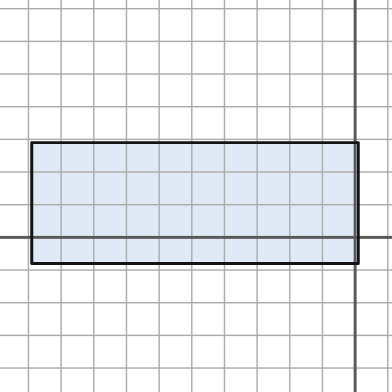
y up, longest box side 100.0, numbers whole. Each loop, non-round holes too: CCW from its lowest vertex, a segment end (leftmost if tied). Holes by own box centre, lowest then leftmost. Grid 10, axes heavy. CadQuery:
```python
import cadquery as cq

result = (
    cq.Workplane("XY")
    .moveTo(-99.0, -8.0)
    .lineTo(1.0, -8.0)
    .lineTo(1.0, 29.0)
    .lineTo(-99.0, 29.0)
    .close()
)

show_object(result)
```